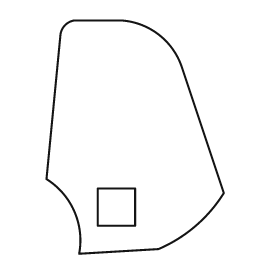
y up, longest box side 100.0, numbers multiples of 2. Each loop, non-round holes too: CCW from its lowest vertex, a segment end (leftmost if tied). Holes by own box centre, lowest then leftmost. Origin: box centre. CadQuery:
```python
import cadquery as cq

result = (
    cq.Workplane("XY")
    .moveTo(-24.0, -50.0)
    .lineTo(10.0, -48.0)
    .threePointArc((26.0, -38.0), (38.0, -24.0))
    .lineTo(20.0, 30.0)
    .threePointArc((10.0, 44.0), (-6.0, 50.0))
    .lineTo(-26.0, 50.0)
    .threePointArc((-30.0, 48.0), (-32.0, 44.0))
    .lineTo(-38.0, -18.0)
    .threePointArc((-26.0, -32.0), (-24.0, -50.0))
    .close()
    .moveTo(-16.0, -38.0)
    .lineTo(0.0, -38.0)
    .lineTo(0.0, -22.0)
    .lineTo(-16.0, -22.0)
    .close()
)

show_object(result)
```